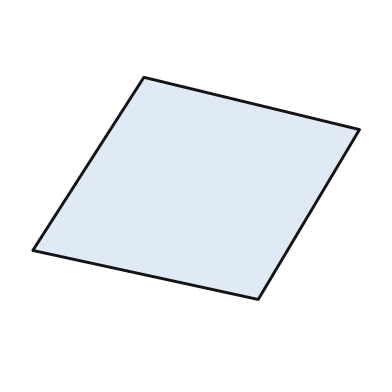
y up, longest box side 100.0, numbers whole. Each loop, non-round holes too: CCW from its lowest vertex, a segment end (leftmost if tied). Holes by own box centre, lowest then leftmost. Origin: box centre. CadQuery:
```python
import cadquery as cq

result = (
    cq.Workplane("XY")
    .moveTo(19.0, -34.0)
    .lineTo(50.0, 18.0)
    .lineTo(-16.0, 34.0)
    .lineTo(-50.0, -19.0)
    .close()
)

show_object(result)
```